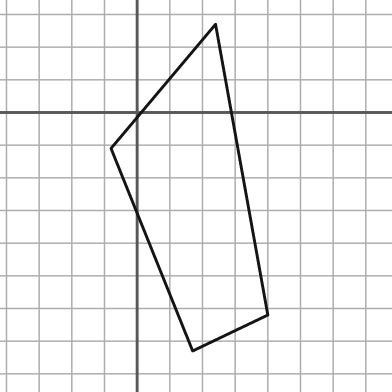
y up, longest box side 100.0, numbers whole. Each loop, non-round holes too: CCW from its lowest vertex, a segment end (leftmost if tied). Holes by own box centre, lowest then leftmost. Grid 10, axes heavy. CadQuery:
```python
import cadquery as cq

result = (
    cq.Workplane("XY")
    .moveTo(17.0, -73.0)
    .lineTo(40.0, -62.0)
    .lineTo(24.0, 27.0)
    .lineTo(-8.0, -11.0)
    .close()
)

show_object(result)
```